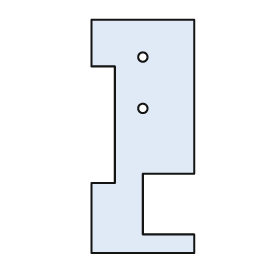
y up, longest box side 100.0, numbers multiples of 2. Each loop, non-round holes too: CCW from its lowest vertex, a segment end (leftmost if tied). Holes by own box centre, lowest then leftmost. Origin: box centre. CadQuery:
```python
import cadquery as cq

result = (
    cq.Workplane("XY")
    .moveTo(-22.0, -50.0)
    .lineTo(22.0, -50.0)
    .lineTo(22.0, -42.0)
    .lineTo(0.0, -42.0)
    .lineTo(0.0, -16.0)
    .lineTo(22.0, -16.0)
    .lineTo(22.0, 50.0)
    .lineTo(-22.0, 50.0)
    .lineTo(-22.0, 30.0)
    .lineTo(-12.0, 30.0)
    .lineTo(-12.0, -20.0)
    .lineTo(-22.0, -20.0)
    .close()
    .moveTo(0.0, 12.0)
    .circle(2.0)
    .moveTo(0.0, 34.0)
    .circle(2.0)
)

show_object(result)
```